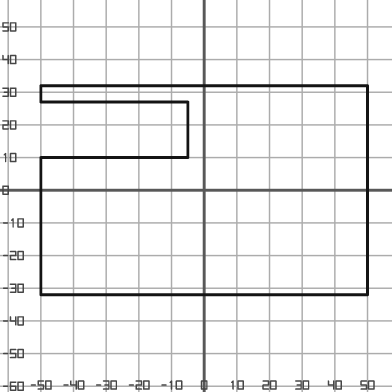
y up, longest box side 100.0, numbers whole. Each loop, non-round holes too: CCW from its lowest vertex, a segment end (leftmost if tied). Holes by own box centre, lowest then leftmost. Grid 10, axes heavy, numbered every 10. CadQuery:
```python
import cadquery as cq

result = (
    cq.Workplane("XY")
    .moveTo(-50.0, -32.0)
    .lineTo(50.0, -32.0)
    .lineTo(50.0, 32.0)
    .lineTo(-50.0, 32.0)
    .lineTo(-50.0, 27.0)
    .lineTo(-5.0, 27.0)
    .lineTo(-5.0, 10.0)
    .lineTo(-50.0, 10.0)
    .close()
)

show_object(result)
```